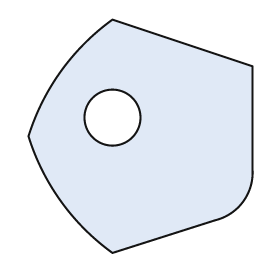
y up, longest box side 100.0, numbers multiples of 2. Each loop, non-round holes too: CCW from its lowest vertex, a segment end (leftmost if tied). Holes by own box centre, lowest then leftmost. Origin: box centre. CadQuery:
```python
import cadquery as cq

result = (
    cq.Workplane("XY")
    .moveTo(-12.0, -50.0)
    .lineTo(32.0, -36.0)
    .threePointArc((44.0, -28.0), (48.0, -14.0))
    .lineTo(48.0, 30.0)
    .lineTo(-12.0, 50.0)
    .threePointArc((-34.0, 28.0), (-48.0, 0.0))
    .threePointArc((-34.0, -28.0), (-12.0, -50.0))
    .close()
    .moveTo(-12.0, 8.0)
    .circle(12.0)
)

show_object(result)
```